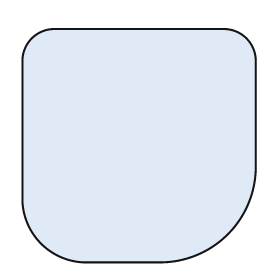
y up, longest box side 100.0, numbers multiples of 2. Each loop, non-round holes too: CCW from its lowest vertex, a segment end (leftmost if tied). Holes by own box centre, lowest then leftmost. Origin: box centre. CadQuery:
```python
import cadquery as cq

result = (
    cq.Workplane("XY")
    .moveTo(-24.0, -50.0)
    .lineTo(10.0, -50.0)
    .threePointArc((38.0, -38.0), (50.0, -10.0))
    .lineTo(50.0, 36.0)
    .threePointArc((46.0, 46.0), (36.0, 50.0))
    .lineTo(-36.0, 50.0)
    .threePointArc((-46.0, 46.0), (-50.0, 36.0))
    .lineTo(-50.0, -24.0)
    .threePointArc((-42.0, -42.0), (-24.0, -50.0))
    .close()
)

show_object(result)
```